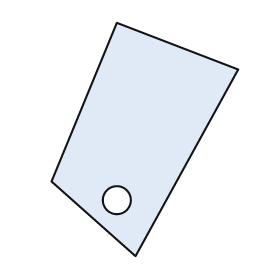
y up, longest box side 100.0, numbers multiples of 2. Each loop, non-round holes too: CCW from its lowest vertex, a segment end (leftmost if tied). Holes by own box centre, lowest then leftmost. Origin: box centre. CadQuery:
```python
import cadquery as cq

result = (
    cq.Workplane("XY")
    .moveTo(-4.0, -50.0)
    .lineTo(40.0, 30.0)
    .lineTo(-12.0, 50.0)
    .lineTo(-40.0, -18.0)
    .close()
    .moveTo(-12.0, -26.0)
    .circle(6.0)
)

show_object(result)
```